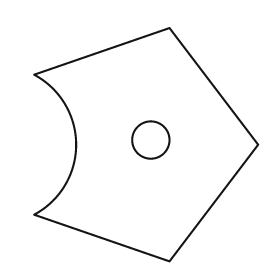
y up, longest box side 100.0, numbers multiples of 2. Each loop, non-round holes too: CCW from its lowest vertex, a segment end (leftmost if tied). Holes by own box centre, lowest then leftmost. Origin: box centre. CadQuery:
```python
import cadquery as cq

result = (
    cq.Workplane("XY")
    .moveTo(10.0, -50.0)
    .lineTo(48.0, 0.0)
    .lineTo(10.0, 50.0)
    .lineTo(-48.0, 30.0)
    .threePointArc((-30.0, 0.0), (-48.0, -30.0))
    .close()
    .moveTo(2.0, 2.0)
    .circle(8.0)
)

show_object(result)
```